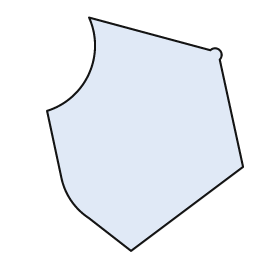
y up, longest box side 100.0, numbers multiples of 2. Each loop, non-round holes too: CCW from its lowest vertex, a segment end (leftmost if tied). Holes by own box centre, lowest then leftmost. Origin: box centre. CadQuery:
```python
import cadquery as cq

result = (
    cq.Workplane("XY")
    .moveTo(-6.0, -50.0)
    .lineTo(42.0, -14.0)
    .lineTo(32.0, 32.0)
    .threePointArc((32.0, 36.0), (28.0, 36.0))
    .lineTo(-24.0, 50.0)
    .threePointArc((-24.0, 26.0), (-42.0, 10.0))
    .lineTo(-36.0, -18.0)
    .threePointArc((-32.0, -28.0), (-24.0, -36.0))
    .close()
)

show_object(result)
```